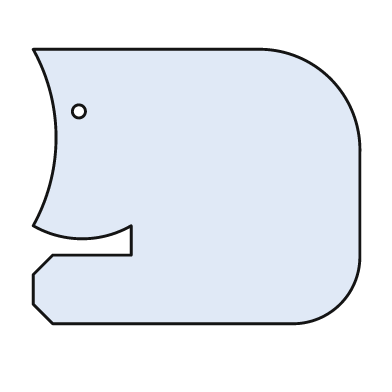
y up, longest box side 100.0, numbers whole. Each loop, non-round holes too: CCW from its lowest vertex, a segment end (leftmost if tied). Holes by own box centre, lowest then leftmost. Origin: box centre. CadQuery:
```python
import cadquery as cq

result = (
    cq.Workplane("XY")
    .moveTo(-44.0, -42.0)
    .lineTo(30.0, -42.0)
    .threePointArc((44.0, -36.0), (50.0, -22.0))
    .lineTo(50.0, 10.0)
    .threePointArc((41.0, 33.0), (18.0, 42.0))
    .lineTo(-50.0, 42.0)
    .threePointArc((-43.0, 15.0), (-50.0, -12.0))
    .threePointArc((-35.0, -16.0), (-20.0, -12.0))
    .lineTo(-20.0, -21.0)
    .lineTo(-44.0, -21.0)
    .lineTo(-50.0, -27.0)
    .lineTo(-50.0, -36.0)
    .close()
    .moveTo(-36.0, 23.0)
    .circle(2.0)
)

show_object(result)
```